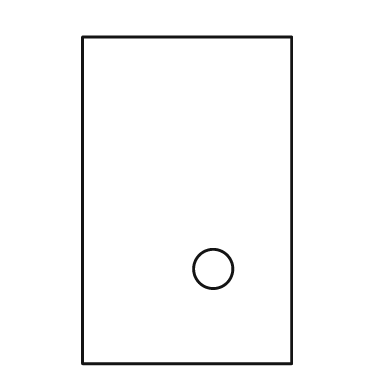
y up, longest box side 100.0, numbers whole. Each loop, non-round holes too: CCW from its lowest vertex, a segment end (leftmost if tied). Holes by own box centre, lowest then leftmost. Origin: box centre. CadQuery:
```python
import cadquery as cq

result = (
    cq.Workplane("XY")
    .moveTo(-32.0, -50.0)
    .lineTo(32.0, -50.0)
    .lineTo(32.0, 50.0)
    .lineTo(-32.0, 50.0)
    .close()
    .moveTo(8.0, -21.0)
    .circle(6.0)
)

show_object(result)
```